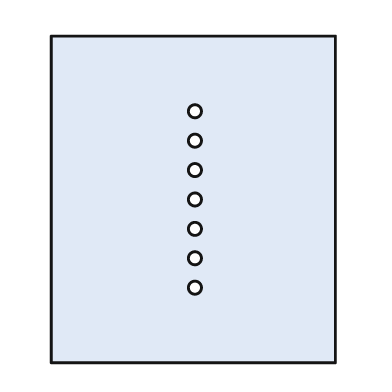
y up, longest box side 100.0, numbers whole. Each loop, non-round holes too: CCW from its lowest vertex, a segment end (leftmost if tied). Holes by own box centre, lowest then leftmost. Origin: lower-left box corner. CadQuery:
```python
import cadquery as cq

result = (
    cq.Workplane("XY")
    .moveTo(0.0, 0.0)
    .lineTo(87.0, 0.0)
    .lineTo(87.0, 100.0)
    .lineTo(0.0, 100.0)
    .close()
    .moveTo(44.0, 23.0)
    .circle(2.0)
    .moveTo(44.0, 32.0)
    .circle(2.0)
    .moveTo(44.0, 41.0)
    .circle(2.0)
    .moveTo(44.0, 50.0)
    .circle(2.0)
    .moveTo(44.0, 59.0)
    .circle(2.0)
    .moveTo(44.0, 68.0)
    .circle(2.0)
    .moveTo(44.0, 77.0)
    .circle(2.0)
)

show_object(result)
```